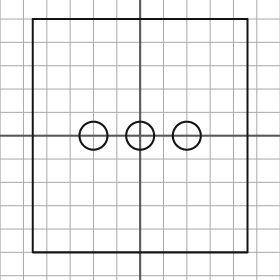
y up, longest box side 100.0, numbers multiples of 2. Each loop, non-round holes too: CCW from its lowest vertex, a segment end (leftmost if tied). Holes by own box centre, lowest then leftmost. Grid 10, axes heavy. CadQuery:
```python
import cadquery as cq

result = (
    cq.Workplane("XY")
    .moveTo(-46.0, -50.0)
    .lineTo(46.0, -50.0)
    .lineTo(46.0, 50.0)
    .lineTo(-46.0, 50.0)
    .close()
    .moveTo(-20.0, 0.0)
    .circle(6.0)
    .moveTo(0.0, 0.0)
    .circle(6.0)
    .moveTo(20.0, 0.0)
    .circle(6.0)
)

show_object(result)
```